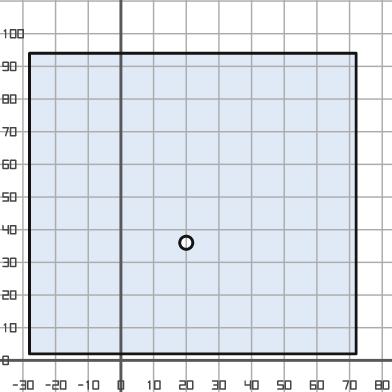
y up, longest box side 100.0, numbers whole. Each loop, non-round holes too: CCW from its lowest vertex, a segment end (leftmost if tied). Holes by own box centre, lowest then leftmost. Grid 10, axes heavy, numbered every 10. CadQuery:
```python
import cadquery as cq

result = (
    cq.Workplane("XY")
    .moveTo(-28.0, 2.0)
    .lineTo(72.0, 2.0)
    .lineTo(72.0, 94.0)
    .lineTo(-28.0, 94.0)
    .close()
    .moveTo(20.0, 36.0)
    .circle(2.0)
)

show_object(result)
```